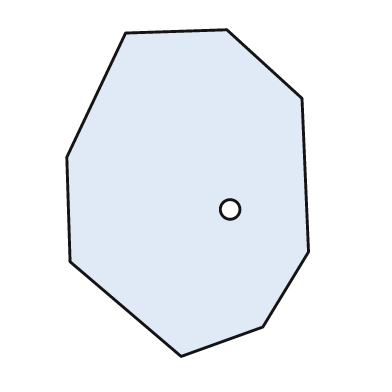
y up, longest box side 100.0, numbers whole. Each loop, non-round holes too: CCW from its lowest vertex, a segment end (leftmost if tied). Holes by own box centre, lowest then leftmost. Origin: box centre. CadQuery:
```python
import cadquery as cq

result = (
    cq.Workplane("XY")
    .moveTo(-2.0, -50.0)
    .lineTo(23.0, -41.0)
    .lineTo(37.0, -18.0)
    .lineTo(35.0, 29.0)
    .lineTo(12.0, 50.0)
    .lineTo(-19.0, 49.0)
    .lineTo(-37.0, 11.0)
    .lineTo(-36.0, -21.0)
    .close()
    .moveTo(13.0, -5.0)
    .circle(3.0)
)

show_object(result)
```